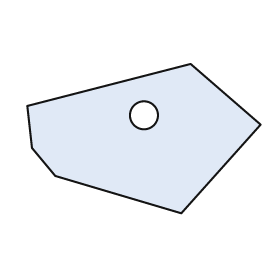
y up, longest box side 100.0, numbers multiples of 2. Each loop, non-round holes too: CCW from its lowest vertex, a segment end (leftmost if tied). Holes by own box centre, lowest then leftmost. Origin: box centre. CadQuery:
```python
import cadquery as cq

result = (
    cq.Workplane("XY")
    .moveTo(16.0, -32.0)
    .lineTo(50.0, 6.0)
    .lineTo(20.0, 32.0)
    .lineTo(-50.0, 14.0)
    .lineTo(-48.0, -4.0)
    .lineTo(-38.0, -16.0)
    .close()
    .moveTo(0.0, 10.0)
    .circle(6.0)
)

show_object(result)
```